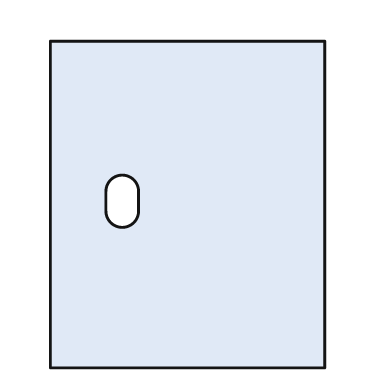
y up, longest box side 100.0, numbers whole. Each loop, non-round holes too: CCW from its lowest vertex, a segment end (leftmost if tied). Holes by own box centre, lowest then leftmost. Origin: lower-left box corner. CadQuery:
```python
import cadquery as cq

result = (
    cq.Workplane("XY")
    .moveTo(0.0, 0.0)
    .lineTo(84.0, 0.0)
    .lineTo(84.0, 100.0)
    .lineTo(0.0, 100.0)
    .close()
    .moveTo(17.0, 48.0)
    .threePointArc((22.0, 43.0), (27.0, 48.0))
    .lineTo(27.0, 54.0)
    .threePointArc((22.0, 59.0), (17.0, 54.0))
    .close()
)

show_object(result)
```